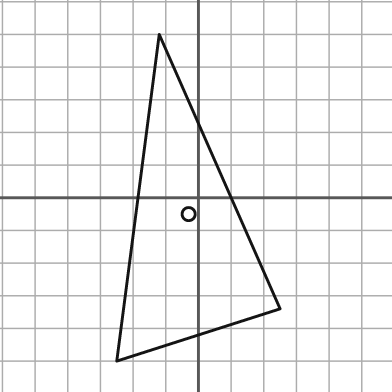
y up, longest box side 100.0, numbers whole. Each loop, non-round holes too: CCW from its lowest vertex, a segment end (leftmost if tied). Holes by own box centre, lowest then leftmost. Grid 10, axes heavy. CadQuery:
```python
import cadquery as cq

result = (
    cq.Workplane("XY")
    .moveTo(-25.0, -50.0)
    .lineTo(25.0, -34.0)
    .lineTo(-12.0, 50.0)
    .close()
    .moveTo(-3.0, -5.0)
    .circle(2.0)
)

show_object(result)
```